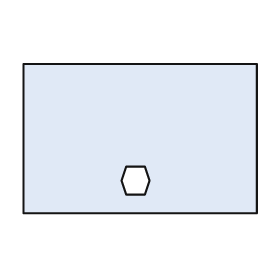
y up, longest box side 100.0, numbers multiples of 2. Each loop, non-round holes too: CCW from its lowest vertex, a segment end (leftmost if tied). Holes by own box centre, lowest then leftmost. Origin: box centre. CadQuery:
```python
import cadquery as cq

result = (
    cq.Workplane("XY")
    .moveTo(-50.0, -32.0)
    .lineTo(50.0, -32.0)
    .lineTo(50.0, 32.0)
    .lineTo(-50.0, 32.0)
    .close()
    .moveTo(-6.0, -24.0)
    .lineTo(2.0, -24.0)
    .lineTo(4.0, -18.0)
    .lineTo(2.0, -12.0)
    .lineTo(-6.0, -12.0)
    .lineTo(-8.0, -18.0)
    .close()
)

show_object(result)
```